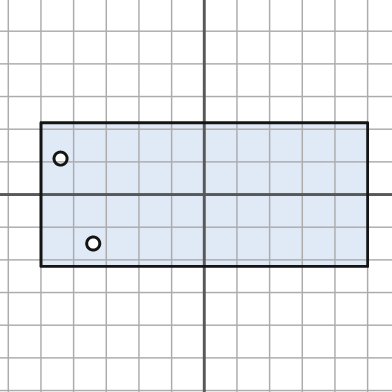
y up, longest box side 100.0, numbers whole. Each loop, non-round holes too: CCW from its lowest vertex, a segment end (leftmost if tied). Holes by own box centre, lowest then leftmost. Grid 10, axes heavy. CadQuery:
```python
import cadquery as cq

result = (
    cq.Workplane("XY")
    .moveTo(-50.0, -22.0)
    .lineTo(50.0, -22.0)
    .lineTo(50.0, 22.0)
    .lineTo(-50.0, 22.0)
    .close()
    .moveTo(-34.0, -15.0)
    .circle(2.0)
    .moveTo(-44.0, 11.0)
    .circle(2.0)
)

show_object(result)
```